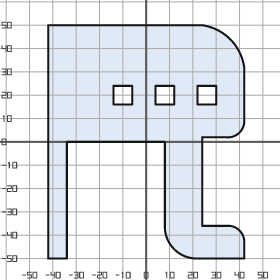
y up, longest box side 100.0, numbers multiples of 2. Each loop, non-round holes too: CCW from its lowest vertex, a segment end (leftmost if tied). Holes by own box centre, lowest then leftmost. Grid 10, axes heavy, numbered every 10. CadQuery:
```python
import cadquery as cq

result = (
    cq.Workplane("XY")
    .moveTo(-42.0, -50.0)
    .lineTo(-34.0, -50.0)
    .lineTo(-34.0, 0.0)
    .lineTo(8.0, 0.0)
    .lineTo(8.0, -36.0)
    .threePointArc((12.0, -46.0), (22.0, -50.0))
    .lineTo(42.0, -50.0)
    .lineTo(42.0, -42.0)
    .threePointArc((40.0, -38.0), (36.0, -36.0))
    .lineTo(24.0, -36.0)
    .lineTo(24.0, 2.0)
    .lineTo(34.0, 2.0)
    .threePointArc((40.0, 4.0), (42.0, 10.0))
    .lineTo(42.0, 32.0)
    .threePointArc((36.0, 44.0), (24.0, 50.0))
    .lineTo(-42.0, 50.0)
    .close()
    .moveTo(-14.0, 16.0)
    .lineTo(-6.0, 16.0)
    .lineTo(-6.0, 24.0)
    .lineTo(-14.0, 24.0)
    .close()
    .moveTo(4.0, 16.0)
    .lineTo(12.0, 16.0)
    .lineTo(12.0, 24.0)
    .lineTo(4.0, 24.0)
    .close()
    .moveTo(22.0, 16.0)
    .lineTo(30.0, 16.0)
    .lineTo(30.0, 24.0)
    .lineTo(22.0, 24.0)
    .close()
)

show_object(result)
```